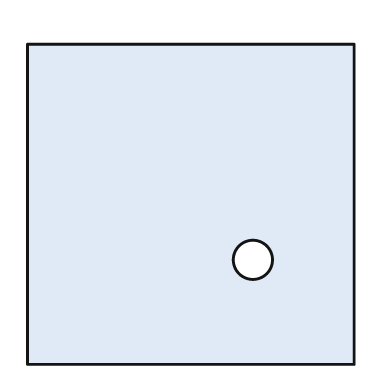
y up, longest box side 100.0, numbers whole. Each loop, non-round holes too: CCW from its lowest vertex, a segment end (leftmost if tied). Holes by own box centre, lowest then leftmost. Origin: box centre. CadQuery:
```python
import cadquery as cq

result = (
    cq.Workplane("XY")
    .moveTo(-50.0, -49.0)
    .lineTo(50.0, -49.0)
    .lineTo(50.0, 49.0)
    .lineTo(-50.0, 49.0)
    .close()
    .moveTo(19.0, -17.0)
    .circle(6.0)
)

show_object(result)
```